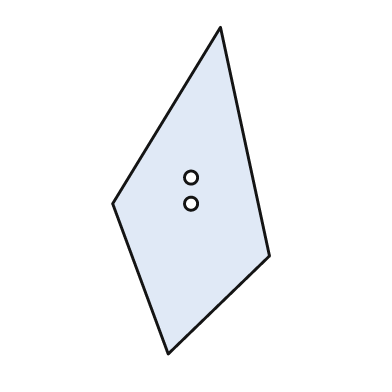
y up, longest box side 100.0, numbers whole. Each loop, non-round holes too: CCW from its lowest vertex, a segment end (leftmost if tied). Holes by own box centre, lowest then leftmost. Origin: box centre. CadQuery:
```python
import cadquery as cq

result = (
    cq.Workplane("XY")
    .moveTo(-7.0, -50.0)
    .lineTo(24.0, -20.0)
    .lineTo(9.0, 50.0)
    .lineTo(-24.0, -4.0)
    .close()
    .moveTo(0.0, -4.0)
    .circle(2.0)
    .moveTo(0.0, 4.0)
    .circle(2.0)
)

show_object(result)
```